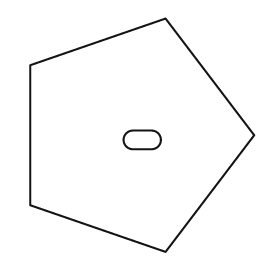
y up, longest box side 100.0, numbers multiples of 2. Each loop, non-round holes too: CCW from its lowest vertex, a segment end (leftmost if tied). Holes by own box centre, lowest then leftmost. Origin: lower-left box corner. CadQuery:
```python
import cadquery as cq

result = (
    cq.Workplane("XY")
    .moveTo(58.0, 0.0)
    .lineTo(96.0, 50.0)
    .lineTo(58.0, 100.0)
    .lineTo(0.0, 80.0)
    .lineTo(0.0, 20.0)
    .close()
    .moveTo(44.0, 44.0)
    .lineTo(52.0, 44.0)
    .threePointArc((56.0, 48.0), (52.0, 52.0))
    .lineTo(44.0, 52.0)
    .threePointArc((40.0, 48.0), (44.0, 44.0))
    .close()
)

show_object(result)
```